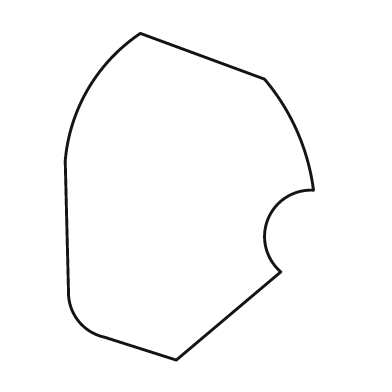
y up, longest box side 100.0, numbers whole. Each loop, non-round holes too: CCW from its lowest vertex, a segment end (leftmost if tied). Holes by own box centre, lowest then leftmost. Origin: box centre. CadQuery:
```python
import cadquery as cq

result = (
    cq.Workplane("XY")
    .moveTo(-4.0, -50.0)
    .lineTo(28.0, -23.0)
    .threePointArc((24.0, -7.0), (38.0, 2.0))
    .threePointArc((33.0, 20.0), (23.0, 36.0))
    .lineTo(-15.0, 50.0)
    .threePointArc((-31.0, 33.0), (-38.0, 11.0))
    .lineTo(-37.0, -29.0)
    .threePointArc((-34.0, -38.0), (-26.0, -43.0))
    .close()
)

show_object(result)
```